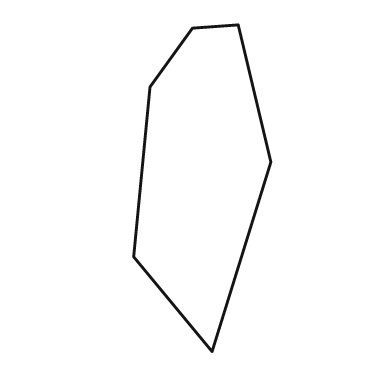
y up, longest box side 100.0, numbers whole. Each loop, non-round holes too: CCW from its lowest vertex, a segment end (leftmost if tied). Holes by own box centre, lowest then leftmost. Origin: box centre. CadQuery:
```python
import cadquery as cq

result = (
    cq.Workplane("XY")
    .moveTo(3.0, -50.0)
    .lineTo(21.0, 8.0)
    .lineTo(11.0, 50.0)
    .lineTo(-3.0, 49.0)
    .lineTo(-16.0, 31.0)
    .lineTo(-21.0, -21.0)
    .close()
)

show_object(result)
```